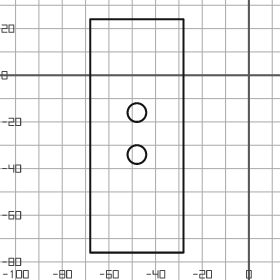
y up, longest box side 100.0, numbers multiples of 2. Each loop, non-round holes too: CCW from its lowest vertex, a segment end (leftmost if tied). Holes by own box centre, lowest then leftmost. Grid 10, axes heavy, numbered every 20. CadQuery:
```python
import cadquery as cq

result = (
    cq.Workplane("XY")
    .moveTo(-68.0, -76.0)
    .lineTo(-28.0, -76.0)
    .lineTo(-28.0, 24.0)
    .lineTo(-68.0, 24.0)
    .close()
    .moveTo(-48.0, -34.0)
    .circle(4.0)
    .moveTo(-48.0, -16.0)
    .circle(4.0)
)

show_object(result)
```